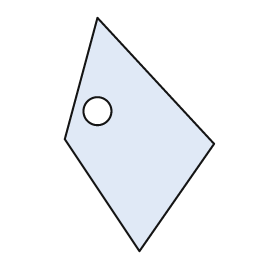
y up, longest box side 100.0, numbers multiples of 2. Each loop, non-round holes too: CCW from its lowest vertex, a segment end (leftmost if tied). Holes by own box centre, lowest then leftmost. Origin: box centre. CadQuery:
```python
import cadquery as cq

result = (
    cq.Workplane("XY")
    .moveTo(0.0, -50.0)
    .lineTo(32.0, -4.0)
    .lineTo(-18.0, 50.0)
    .lineTo(-32.0, -2.0)
    .close()
    .moveTo(-18.0, 10.0)
    .circle(6.0)
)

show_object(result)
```